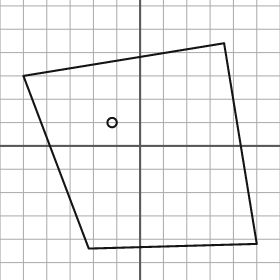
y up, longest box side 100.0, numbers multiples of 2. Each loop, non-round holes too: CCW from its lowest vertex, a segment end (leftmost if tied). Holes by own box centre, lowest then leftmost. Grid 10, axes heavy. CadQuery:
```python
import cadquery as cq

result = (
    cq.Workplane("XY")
    .moveTo(-22.0, -44.0)
    .lineTo(50.0, -42.0)
    .lineTo(36.0, 44.0)
    .lineTo(-50.0, 30.0)
    .close()
    .moveTo(-12.0, 10.0)
    .circle(2.0)
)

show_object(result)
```